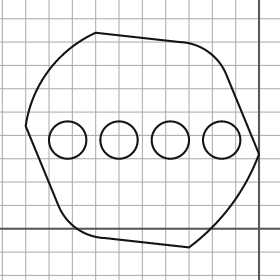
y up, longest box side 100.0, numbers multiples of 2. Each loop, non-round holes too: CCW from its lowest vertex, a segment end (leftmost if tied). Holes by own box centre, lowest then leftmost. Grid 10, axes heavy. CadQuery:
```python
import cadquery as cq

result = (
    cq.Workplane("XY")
    .moveTo(-30.0, -8.0)
    .threePointArc((-12.0, 10.0), (0.0, 32.0))
    .lineTo(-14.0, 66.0)
    .threePointArc((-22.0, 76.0), (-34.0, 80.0))
    .lineTo(-70.0, 84.0)
    .threePointArc((-90.0, 68.0), (-100.0, 44.0))
    .lineTo(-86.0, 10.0)
    .threePointArc((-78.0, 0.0), (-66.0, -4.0))
    .close()
    .moveTo(-82.0, 38.0)
    .circle(8.0)
    .moveTo(-60.0, 38.0)
    .circle(8.0)
    .moveTo(-38.0, 38.0)
    .circle(8.0)
    .moveTo(-16.0, 38.0)
    .circle(8.0)
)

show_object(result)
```